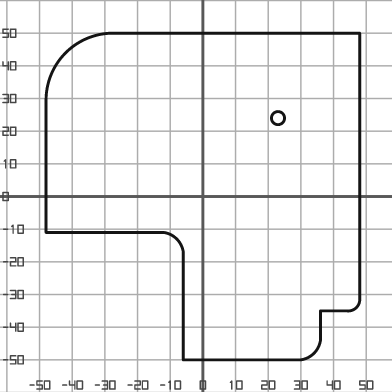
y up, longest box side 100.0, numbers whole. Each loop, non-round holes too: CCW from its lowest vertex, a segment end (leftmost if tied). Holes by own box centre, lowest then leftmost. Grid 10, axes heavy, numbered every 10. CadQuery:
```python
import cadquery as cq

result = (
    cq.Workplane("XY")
    .moveTo(-6.0, -50.0)
    .lineTo(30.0, -50.0)
    .threePointArc((34.0, -48.0), (36.0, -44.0))
    .lineTo(36.0, -35.0)
    .lineTo(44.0, -35.0)
    .threePointArc((47.0, -34.0), (48.0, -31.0))
    .lineTo(48.0, 50.0)
    .lineTo(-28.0, 50.0)
    .threePointArc((-42.0, 44.0), (-48.0, 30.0))
    .lineTo(-48.0, -11.0)
    .lineTo(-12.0, -11.0)
    .threePointArc((-8.0, -13.0), (-6.0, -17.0))
    .close()
    .moveTo(23.0, 24.0)
    .circle(2.0)
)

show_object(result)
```